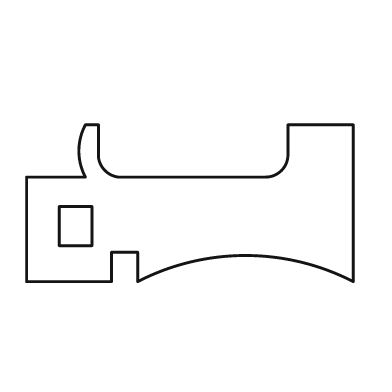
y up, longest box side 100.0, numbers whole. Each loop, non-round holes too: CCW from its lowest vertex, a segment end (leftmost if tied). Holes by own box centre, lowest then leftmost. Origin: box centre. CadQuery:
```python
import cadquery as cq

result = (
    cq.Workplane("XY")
    .moveTo(-50.0, -24.0)
    .lineTo(-24.0, -24.0)
    .lineTo(-24.0, -15.0)
    .lineTo(-16.0, -15.0)
    .lineTo(-16.0, -24.0)
    .threePointArc((17.0, -16.0), (50.0, -24.0))
    .lineTo(50.0, 24.0)
    .lineTo(30.0, 24.0)
    .lineTo(30.0, 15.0)
    .threePointArc((28.0, 10.0), (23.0, 8.0))
    .lineTo(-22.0, 8.0)
    .threePointArc((-26.0, 10.0), (-28.0, 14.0))
    .lineTo(-28.0, 24.0)
    .lineTo(-32.0, 24.0)
    .threePointArc((-34.0, 16.0), (-32.0, 8.0))
    .lineTo(-50.0, 8.0)
    .close()
    .moveTo(-40.0, -13.0)
    .lineTo(-30.0, -13.0)
    .lineTo(-30.0, -1.0)
    .lineTo(-40.0, -1.0)
    .close()
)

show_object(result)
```